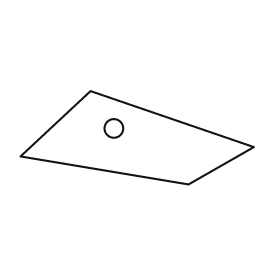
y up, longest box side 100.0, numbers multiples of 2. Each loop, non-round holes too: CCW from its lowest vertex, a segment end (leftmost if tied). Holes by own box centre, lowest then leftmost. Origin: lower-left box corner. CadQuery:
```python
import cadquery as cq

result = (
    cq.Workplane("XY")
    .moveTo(72.0, 0.0)
    .lineTo(100.0, 16.0)
    .lineTo(30.0, 40.0)
    .lineTo(0.0, 12.0)
    .close()
    .moveTo(40.0, 24.0)
    .circle(4.0)
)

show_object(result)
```